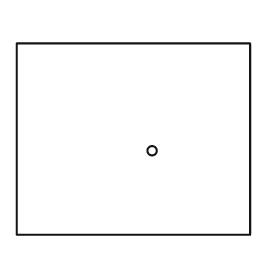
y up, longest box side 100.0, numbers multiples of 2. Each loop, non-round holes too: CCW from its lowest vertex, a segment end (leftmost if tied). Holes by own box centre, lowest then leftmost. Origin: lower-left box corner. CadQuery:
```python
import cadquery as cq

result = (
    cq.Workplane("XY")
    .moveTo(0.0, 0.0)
    .lineTo(100.0, 0.0)
    .lineTo(100.0, 82.0)
    .lineTo(0.0, 82.0)
    .close()
    .moveTo(58.0, 36.0)
    .circle(2.0)
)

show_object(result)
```